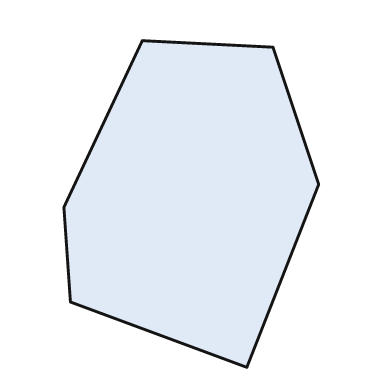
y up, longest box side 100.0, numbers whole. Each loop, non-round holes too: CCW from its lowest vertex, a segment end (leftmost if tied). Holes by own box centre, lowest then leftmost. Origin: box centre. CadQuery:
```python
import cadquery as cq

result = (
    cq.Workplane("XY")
    .moveTo(17.0, -50.0)
    .lineTo(39.0, 6.0)
    .lineTo(25.0, 48.0)
    .lineTo(-15.0, 50.0)
    .lineTo(-39.0, -1.0)
    .lineTo(-37.0, -30.0)
    .close()
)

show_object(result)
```